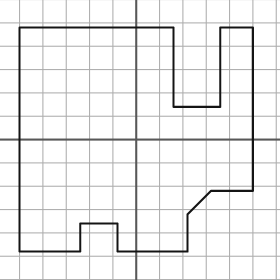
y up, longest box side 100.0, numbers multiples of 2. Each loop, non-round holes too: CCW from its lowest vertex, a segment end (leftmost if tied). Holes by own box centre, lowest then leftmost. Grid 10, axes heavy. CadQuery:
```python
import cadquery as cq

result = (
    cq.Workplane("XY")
    .moveTo(-50.0, -48.0)
    .lineTo(-24.0, -48.0)
    .lineTo(-24.0, -36.0)
    .lineTo(-8.0, -36.0)
    .lineTo(-8.0, -48.0)
    .lineTo(22.0, -48.0)
    .lineTo(22.0, -32.0)
    .lineTo(32.0, -22.0)
    .lineTo(50.0, -22.0)
    .lineTo(50.0, 48.0)
    .lineTo(36.0, 48.0)
    .lineTo(36.0, 14.0)
    .lineTo(16.0, 14.0)
    .lineTo(16.0, 48.0)
    .lineTo(-50.0, 48.0)
    .close()
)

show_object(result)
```